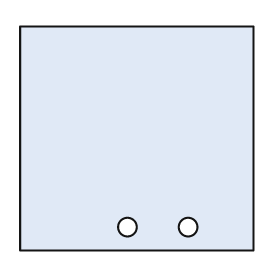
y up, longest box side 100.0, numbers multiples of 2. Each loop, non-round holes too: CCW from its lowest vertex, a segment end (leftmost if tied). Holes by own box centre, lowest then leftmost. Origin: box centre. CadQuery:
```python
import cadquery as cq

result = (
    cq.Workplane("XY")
    .moveTo(-50.0, -48.0)
    .lineTo(50.0, -48.0)
    .lineTo(50.0, 48.0)
    .lineTo(-50.0, 48.0)
    .close()
    .moveTo(-4.0, -38.0)
    .circle(4.0)
    .moveTo(22.0, -38.0)
    .circle(4.0)
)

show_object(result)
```